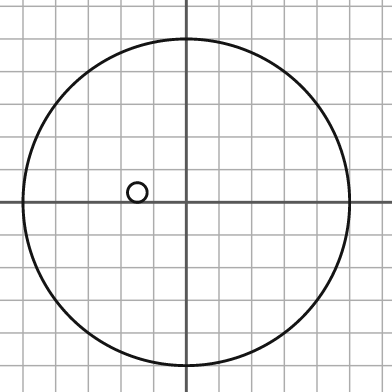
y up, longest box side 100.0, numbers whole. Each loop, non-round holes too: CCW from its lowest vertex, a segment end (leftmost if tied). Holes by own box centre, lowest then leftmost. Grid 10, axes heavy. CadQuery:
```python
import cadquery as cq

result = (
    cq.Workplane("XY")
    .moveTo(0.0, 0.0)
    .circle(50.0)
    .moveTo(-15.0, 3.0)
    .circle(3.0)
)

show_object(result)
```